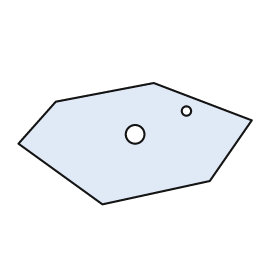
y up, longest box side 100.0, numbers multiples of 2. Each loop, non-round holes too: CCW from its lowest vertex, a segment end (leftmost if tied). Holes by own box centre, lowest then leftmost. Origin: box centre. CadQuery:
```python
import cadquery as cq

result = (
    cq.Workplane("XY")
    .moveTo(-14.0, -26.0)
    .lineTo(32.0, -16.0)
    .lineTo(50.0, 10.0)
    .lineTo(8.0, 26.0)
    .lineTo(-34.0, 18.0)
    .lineTo(-50.0, 0.0)
    .close()
    .moveTo(0.0, 4.0)
    .circle(4.0)
    .moveTo(22.0, 14.0)
    .circle(2.0)
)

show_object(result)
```